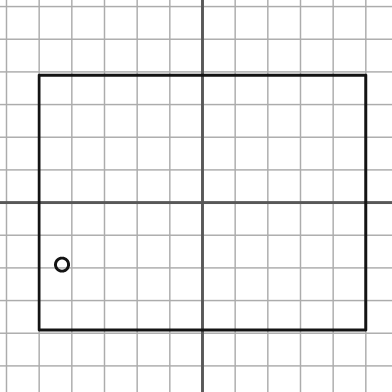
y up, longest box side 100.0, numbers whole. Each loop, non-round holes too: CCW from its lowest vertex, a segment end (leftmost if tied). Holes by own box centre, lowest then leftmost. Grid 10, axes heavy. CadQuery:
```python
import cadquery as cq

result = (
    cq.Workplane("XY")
    .moveTo(-50.0, -39.0)
    .lineTo(50.0, -39.0)
    .lineTo(50.0, 39.0)
    .lineTo(-50.0, 39.0)
    .close()
    .moveTo(-43.0, -19.0)
    .circle(2.0)
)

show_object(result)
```